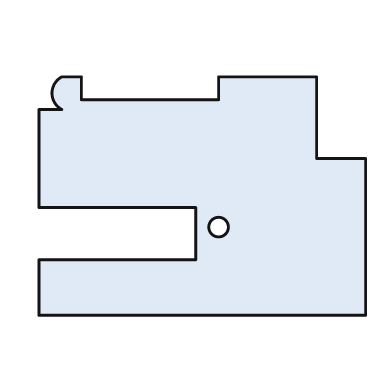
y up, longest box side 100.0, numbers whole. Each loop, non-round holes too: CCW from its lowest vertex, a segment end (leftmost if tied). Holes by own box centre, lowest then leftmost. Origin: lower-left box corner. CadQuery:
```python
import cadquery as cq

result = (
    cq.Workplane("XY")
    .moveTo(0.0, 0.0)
    .lineTo(100.0, 0.0)
    .lineTo(100.0, 48.0)
    .lineTo(85.0, 48.0)
    .lineTo(85.0, 73.0)
    .lineTo(55.0, 73.0)
    .lineTo(55.0, 66.0)
    .lineTo(13.0, 66.0)
    .lineTo(13.0, 73.0)
    .lineTo(7.0, 73.0)
    .threePointArc((4.0, 68.0), (7.0, 63.0))
    .lineTo(0.0, 63.0)
    .lineTo(0.0, 33.0)
    .lineTo(48.0, 33.0)
    .lineTo(48.0, 17.0)
    .lineTo(0.0, 17.0)
    .close()
    .moveTo(55.0, 27.0)
    .circle(3.0)
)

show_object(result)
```